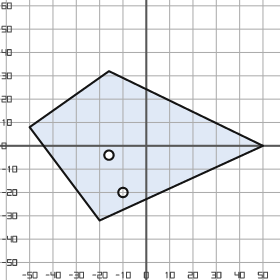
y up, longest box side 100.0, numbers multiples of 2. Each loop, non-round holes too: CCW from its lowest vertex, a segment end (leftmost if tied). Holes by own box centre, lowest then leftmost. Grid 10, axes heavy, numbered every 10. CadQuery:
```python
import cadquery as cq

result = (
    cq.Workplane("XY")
    .moveTo(-20.0, -32.0)
    .lineTo(50.0, 0.0)
    .lineTo(-16.0, 32.0)
    .lineTo(-50.0, 8.0)
    .close()
    .moveTo(-10.0, -20.0)
    .circle(2.0)
    .moveTo(-16.0, -4.0)
    .circle(2.0)
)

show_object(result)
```